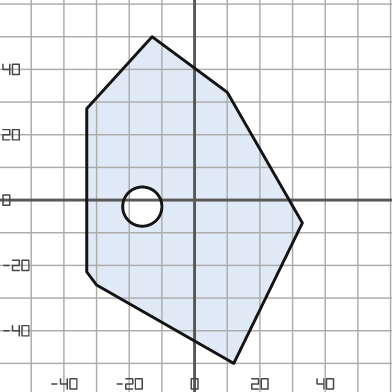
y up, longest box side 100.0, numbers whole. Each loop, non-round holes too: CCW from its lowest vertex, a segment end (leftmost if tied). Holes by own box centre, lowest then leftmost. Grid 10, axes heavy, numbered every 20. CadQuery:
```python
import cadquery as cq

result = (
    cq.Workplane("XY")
    .moveTo(12.0, -50.0)
    .lineTo(33.0, -7.0)
    .lineTo(10.0, 33.0)
    .lineTo(-13.0, 50.0)
    .lineTo(-33.0, 28.0)
    .lineTo(-33.0, -22.0)
    .lineTo(-30.0, -26.0)
    .close()
    .moveTo(-16.0, -2.0)
    .circle(6.0)
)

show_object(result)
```